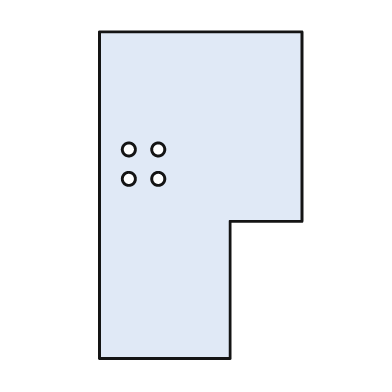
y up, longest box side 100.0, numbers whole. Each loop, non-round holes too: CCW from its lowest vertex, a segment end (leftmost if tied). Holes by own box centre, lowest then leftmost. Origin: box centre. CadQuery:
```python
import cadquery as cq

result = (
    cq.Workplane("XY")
    .moveTo(-31.0, -50.0)
    .lineTo(9.0, -50.0)
    .lineTo(9.0, -8.0)
    .lineTo(31.0, -8.0)
    .lineTo(31.0, 50.0)
    .lineTo(-31.0, 50.0)
    .close()
    .moveTo(-22.0, 5.0)
    .circle(2.0)
    .moveTo(-13.0, 5.0)
    .circle(2.0)
    .moveTo(-22.0, 14.0)
    .circle(2.0)
    .moveTo(-13.0, 14.0)
    .circle(2.0)
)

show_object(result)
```